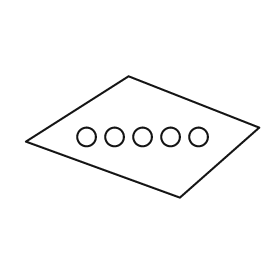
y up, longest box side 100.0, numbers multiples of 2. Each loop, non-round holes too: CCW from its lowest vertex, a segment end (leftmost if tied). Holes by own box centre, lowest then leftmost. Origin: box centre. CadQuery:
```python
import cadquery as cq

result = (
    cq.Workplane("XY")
    .moveTo(16.0, -26.0)
    .lineTo(50.0, 4.0)
    .lineTo(-6.0, 26.0)
    .lineTo(-50.0, -2.0)
    .close()
    .moveTo(-24.0, 0.0)
    .circle(4.0)
    .moveTo(-12.0, 0.0)
    .circle(4.0)
    .moveTo(0.0, 0.0)
    .circle(4.0)
    .moveTo(12.0, 0.0)
    .circle(4.0)
    .moveTo(24.0, 0.0)
    .circle(4.0)
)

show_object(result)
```